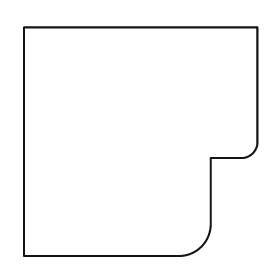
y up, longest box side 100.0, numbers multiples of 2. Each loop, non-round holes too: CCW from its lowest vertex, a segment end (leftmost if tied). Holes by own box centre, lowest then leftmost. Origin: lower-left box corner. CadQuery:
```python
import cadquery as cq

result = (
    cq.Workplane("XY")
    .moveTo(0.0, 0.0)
    .lineTo(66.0, 0.0)
    .threePointArc((76.0, 4.0), (80.0, 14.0))
    .lineTo(80.0, 42.0)
    .lineTo(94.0, 42.0)
    .threePointArc((98.0, 44.0), (100.0, 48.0))
    .lineTo(100.0, 98.0)
    .lineTo(0.0, 98.0)
    .close()
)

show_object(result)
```